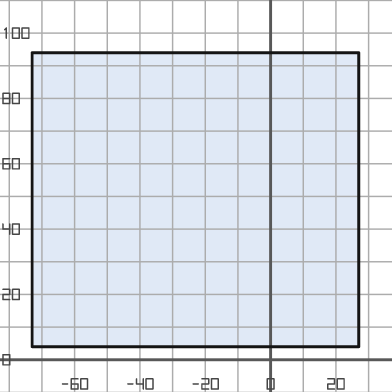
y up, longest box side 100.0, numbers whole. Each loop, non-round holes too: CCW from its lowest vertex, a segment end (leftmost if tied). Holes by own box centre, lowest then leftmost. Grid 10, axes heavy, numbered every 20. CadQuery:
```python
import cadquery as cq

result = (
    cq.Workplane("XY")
    .moveTo(-73.0, 4.0)
    .lineTo(27.0, 4.0)
    .lineTo(27.0, 94.0)
    .lineTo(-73.0, 94.0)
    .close()
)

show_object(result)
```